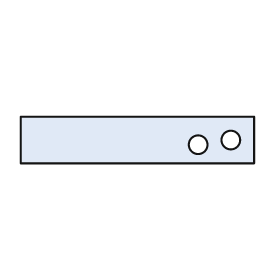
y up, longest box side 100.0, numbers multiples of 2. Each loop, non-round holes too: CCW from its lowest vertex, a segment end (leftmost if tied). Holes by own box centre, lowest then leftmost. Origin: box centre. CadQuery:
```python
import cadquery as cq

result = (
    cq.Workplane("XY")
    .moveTo(-50.0, -10.0)
    .lineTo(50.0, -10.0)
    .lineTo(50.0, 10.0)
    .lineTo(-50.0, 10.0)
    .close()
    .moveTo(26.0, -2.0)
    .circle(4.0)
    .moveTo(40.0, 0.0)
    .circle(4.0)
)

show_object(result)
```